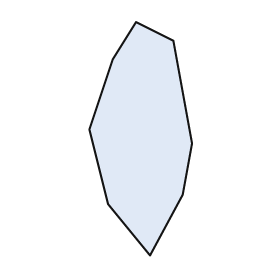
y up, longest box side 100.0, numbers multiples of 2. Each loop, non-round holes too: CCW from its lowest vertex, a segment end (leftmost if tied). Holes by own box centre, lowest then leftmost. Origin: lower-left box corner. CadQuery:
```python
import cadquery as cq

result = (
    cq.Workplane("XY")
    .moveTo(26.0, 0.0)
    .lineTo(40.0, 26.0)
    .lineTo(44.0, 48.0)
    .lineTo(36.0, 92.0)
    .lineTo(20.0, 100.0)
    .lineTo(10.0, 84.0)
    .lineTo(0.0, 54.0)
    .lineTo(8.0, 22.0)
    .close()
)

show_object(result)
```